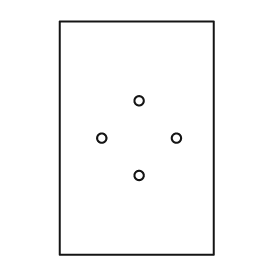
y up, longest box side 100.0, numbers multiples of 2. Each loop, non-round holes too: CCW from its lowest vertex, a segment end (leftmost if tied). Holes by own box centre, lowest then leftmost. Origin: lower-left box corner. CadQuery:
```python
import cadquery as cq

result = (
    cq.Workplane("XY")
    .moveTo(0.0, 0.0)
    .lineTo(66.0, 0.0)
    .lineTo(66.0, 100.0)
    .lineTo(0.0, 100.0)
    .close()
    .moveTo(34.0, 34.0)
    .circle(2.0)
    .moveTo(18.0, 50.0)
    .circle(2.0)
    .moveTo(50.0, 50.0)
    .circle(2.0)
    .moveTo(34.0, 66.0)
    .circle(2.0)
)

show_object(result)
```